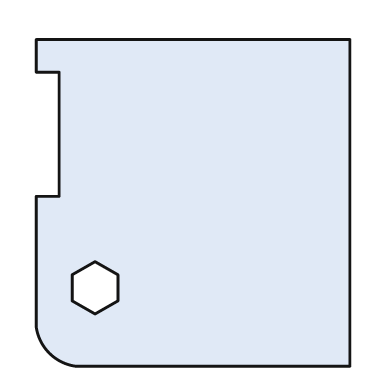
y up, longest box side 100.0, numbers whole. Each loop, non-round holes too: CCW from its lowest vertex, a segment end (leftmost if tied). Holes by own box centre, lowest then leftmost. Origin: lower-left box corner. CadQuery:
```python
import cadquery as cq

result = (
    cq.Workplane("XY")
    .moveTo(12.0, 0.0)
    .lineTo(96.0, 0.0)
    .lineTo(96.0, 100.0)
    .lineTo(0.0, 100.0)
    .lineTo(0.0, 90.0)
    .lineTo(7.0, 90.0)
    .lineTo(7.0, 52.0)
    .lineTo(0.0, 52.0)
    .lineTo(0.0, 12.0)
    .threePointArc((4.0, 4.0), (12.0, 0.0))
    .close()
    .moveTo(18.0, 16.0)
    .lineTo(25.0, 20.0)
    .lineTo(25.0, 28.0)
    .lineTo(18.0, 32.0)
    .lineTo(11.0, 28.0)
    .lineTo(11.0, 20.0)
    .close()
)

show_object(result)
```